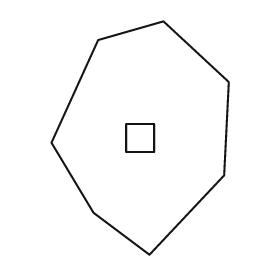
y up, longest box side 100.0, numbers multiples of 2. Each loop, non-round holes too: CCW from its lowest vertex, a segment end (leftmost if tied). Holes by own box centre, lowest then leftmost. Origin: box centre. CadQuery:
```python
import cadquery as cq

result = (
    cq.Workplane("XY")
    .moveTo(4.0, -50.0)
    .lineTo(36.0, -16.0)
    .lineTo(38.0, 24.0)
    .lineTo(10.0, 50.0)
    .lineTo(-18.0, 42.0)
    .lineTo(-38.0, -2.0)
    .lineTo(-20.0, -32.0)
    .close()
    .moveTo(-6.0, -6.0)
    .lineTo(6.0, -6.0)
    .lineTo(6.0, 6.0)
    .lineTo(-6.0, 6.0)
    .close()
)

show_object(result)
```